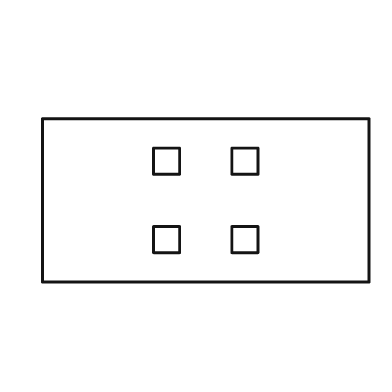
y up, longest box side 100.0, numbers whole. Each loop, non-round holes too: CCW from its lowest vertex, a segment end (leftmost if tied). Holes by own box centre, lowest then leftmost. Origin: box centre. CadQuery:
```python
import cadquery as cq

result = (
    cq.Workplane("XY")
    .moveTo(-50.0, -25.0)
    .lineTo(50.0, -25.0)
    .lineTo(50.0, 25.0)
    .lineTo(-50.0, 25.0)
    .close()
    .moveTo(-16.0, -16.0)
    .lineTo(-8.0, -16.0)
    .lineTo(-8.0, -8.0)
    .lineTo(-16.0, -8.0)
    .close()
    .moveTo(8.0, -16.0)
    .lineTo(16.0, -16.0)
    .lineTo(16.0, -8.0)
    .lineTo(8.0, -8.0)
    .close()
    .moveTo(-16.0, 8.0)
    .lineTo(-8.0, 8.0)
    .lineTo(-8.0, 16.0)
    .lineTo(-16.0, 16.0)
    .close()
    .moveTo(8.0, 8.0)
    .lineTo(16.0, 8.0)
    .lineTo(16.0, 16.0)
    .lineTo(8.0, 16.0)
    .close()
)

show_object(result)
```